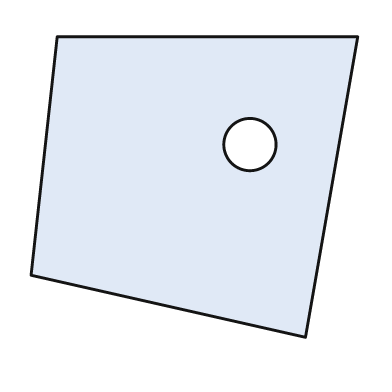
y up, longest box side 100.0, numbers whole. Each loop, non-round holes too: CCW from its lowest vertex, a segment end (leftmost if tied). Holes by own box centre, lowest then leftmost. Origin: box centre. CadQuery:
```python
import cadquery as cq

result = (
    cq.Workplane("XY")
    .moveTo(34.0, -46.0)
    .lineTo(50.0, 46.0)
    .lineTo(-42.0, 46.0)
    .lineTo(-50.0, -27.0)
    .close()
    .moveTo(17.0, 13.0)
    .circle(8.0)
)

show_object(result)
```